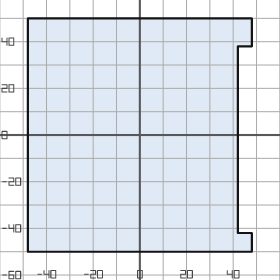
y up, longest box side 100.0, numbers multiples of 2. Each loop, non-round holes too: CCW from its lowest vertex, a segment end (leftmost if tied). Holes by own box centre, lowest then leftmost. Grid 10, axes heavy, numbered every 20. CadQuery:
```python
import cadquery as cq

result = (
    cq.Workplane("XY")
    .moveTo(-48.0, -50.0)
    .lineTo(48.0, -50.0)
    .lineTo(48.0, -42.0)
    .lineTo(42.0, -42.0)
    .lineTo(42.0, 38.0)
    .lineTo(48.0, 38.0)
    .lineTo(48.0, 50.0)
    .lineTo(-48.0, 50.0)
    .close()
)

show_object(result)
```